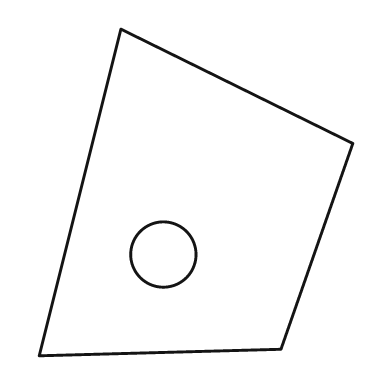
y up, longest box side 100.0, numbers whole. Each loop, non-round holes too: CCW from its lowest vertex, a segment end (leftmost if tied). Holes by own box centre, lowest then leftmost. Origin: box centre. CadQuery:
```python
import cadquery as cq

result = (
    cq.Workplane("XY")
    .moveTo(-48.0, -50.0)
    .lineTo(26.0, -48.0)
    .lineTo(48.0, 15.0)
    .lineTo(-23.0, 50.0)
    .close()
    .moveTo(-10.0, -19.0)
    .circle(10.0)
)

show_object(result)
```